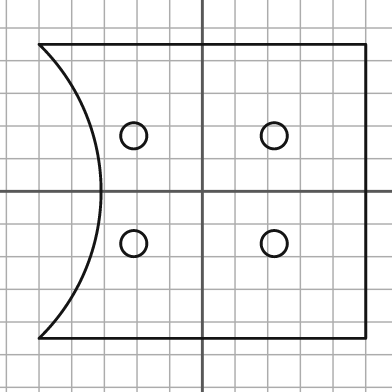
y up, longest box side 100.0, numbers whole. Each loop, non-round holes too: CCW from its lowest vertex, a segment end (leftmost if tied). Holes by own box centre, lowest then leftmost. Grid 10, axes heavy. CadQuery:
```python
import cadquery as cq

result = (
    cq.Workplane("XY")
    .moveTo(-50.0, -45.0)
    .lineTo(50.0, -45.0)
    .lineTo(50.0, 45.0)
    .lineTo(-50.0, 45.0)
    .threePointArc((-31.0, 0.0), (-50.0, -45.0))
    .close()
    .moveTo(-21.0, -16.0)
    .circle(4.0)
    .moveTo(22.0, -16.0)
    .circle(4.0)
    .moveTo(-21.0, 17.0)
    .circle(4.0)
    .moveTo(22.0, 17.0)
    .circle(4.0)
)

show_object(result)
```